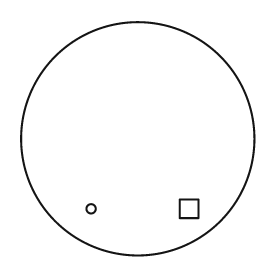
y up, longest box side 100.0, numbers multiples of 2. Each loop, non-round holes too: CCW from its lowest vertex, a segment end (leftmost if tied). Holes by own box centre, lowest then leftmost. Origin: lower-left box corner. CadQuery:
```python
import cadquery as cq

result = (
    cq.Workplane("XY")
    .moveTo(50.0, 50.0)
    .circle(50.0)
    .moveTo(30.0, 20.0)
    .circle(2.0)
    .moveTo(68.0, 16.0)
    .lineTo(76.0, 16.0)
    .lineTo(76.0, 24.0)
    .lineTo(68.0, 24.0)
    .close()
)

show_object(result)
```